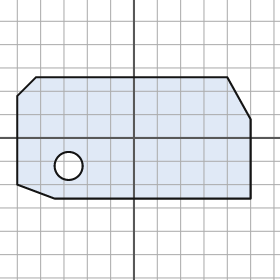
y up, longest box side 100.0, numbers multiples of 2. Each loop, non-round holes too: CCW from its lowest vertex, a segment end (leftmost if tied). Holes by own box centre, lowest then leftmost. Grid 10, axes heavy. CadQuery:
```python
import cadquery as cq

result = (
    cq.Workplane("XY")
    .moveTo(-34.0, -26.0)
    .lineTo(50.0, -26.0)
    .lineTo(50.0, 8.0)
    .lineTo(40.0, 26.0)
    .lineTo(-42.0, 26.0)
    .lineTo(-50.0, 18.0)
    .lineTo(-50.0, -20.0)
    .close()
    .moveTo(-28.0, -12.0)
    .circle(6.0)
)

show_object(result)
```